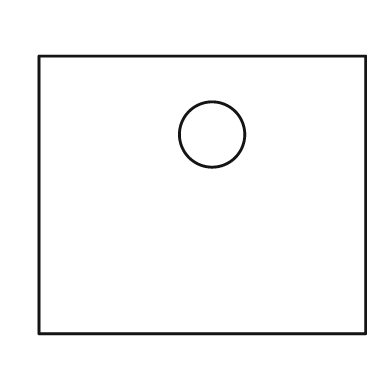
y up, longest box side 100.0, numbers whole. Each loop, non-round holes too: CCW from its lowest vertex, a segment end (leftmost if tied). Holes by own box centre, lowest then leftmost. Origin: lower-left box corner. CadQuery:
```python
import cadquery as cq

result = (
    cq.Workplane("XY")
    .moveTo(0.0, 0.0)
    .lineTo(100.0, 0.0)
    .lineTo(100.0, 85.0)
    .lineTo(0.0, 85.0)
    .close()
    .moveTo(53.0, 61.0)
    .circle(10.0)
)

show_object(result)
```